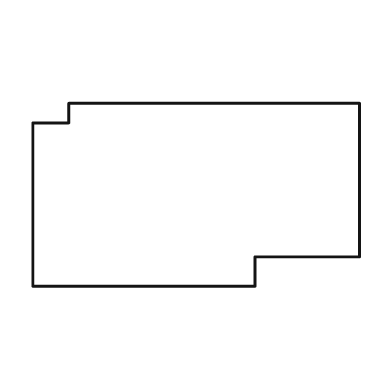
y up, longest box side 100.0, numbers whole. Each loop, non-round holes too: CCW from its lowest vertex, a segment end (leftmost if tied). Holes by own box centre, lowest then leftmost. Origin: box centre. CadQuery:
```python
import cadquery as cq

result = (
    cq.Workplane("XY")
    .moveTo(-50.0, -28.0)
    .lineTo(18.0, -28.0)
    .lineTo(18.0, -19.0)
    .lineTo(50.0, -19.0)
    .lineTo(50.0, 28.0)
    .lineTo(-39.0, 28.0)
    .lineTo(-39.0, 22.0)
    .lineTo(-50.0, 22.0)
    .close()
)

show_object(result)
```